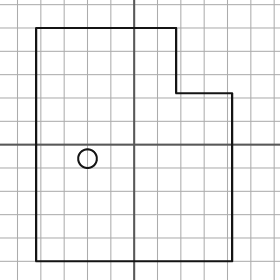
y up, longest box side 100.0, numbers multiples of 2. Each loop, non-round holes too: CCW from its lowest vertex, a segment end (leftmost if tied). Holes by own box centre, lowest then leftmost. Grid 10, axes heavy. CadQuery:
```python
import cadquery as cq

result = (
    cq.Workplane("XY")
    .moveTo(-42.0, -50.0)
    .lineTo(42.0, -50.0)
    .lineTo(42.0, 22.0)
    .lineTo(18.0, 22.0)
    .lineTo(18.0, 50.0)
    .lineTo(-42.0, 50.0)
    .close()
    .moveTo(-20.0, -6.0)
    .circle(4.0)
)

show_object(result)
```